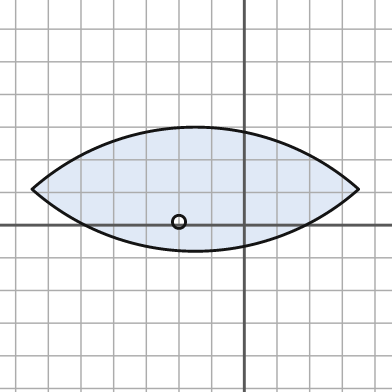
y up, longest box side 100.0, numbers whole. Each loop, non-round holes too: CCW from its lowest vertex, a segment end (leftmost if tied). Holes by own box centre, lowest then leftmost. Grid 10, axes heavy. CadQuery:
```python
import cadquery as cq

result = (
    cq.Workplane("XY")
    .moveTo(-65.0, 11.0)
    .threePointArc((-15.0, -8.0), (35.0, 11.0))
    .threePointArc((-15.0, 30.0), (-65.0, 11.0))
    .close()
    .moveTo(-20.0, 1.0)
    .circle(2.0)
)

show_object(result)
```